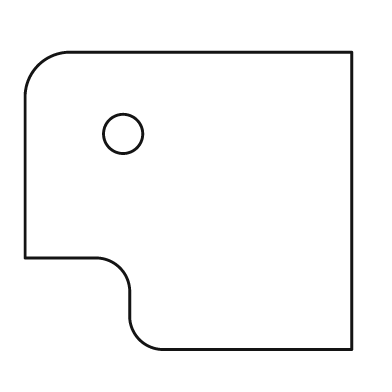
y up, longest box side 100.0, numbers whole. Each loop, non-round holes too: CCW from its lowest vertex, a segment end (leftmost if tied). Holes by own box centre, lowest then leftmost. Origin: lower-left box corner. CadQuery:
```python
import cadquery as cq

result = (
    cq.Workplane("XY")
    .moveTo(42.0, 0.0)
    .lineTo(100.0, 0.0)
    .lineTo(100.0, 91.0)
    .lineTo(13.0, 91.0)
    .threePointArc((4.0, 87.0), (0.0, 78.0))
    .lineTo(0.0, 28.0)
    .lineTo(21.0, 28.0)
    .threePointArc((29.0, 25.0), (32.0, 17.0))
    .lineTo(32.0, 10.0)
    .threePointArc((35.0, 3.0), (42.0, 0.0))
    .close()
    .moveTo(30.0, 66.0)
    .circle(6.0)
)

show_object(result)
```